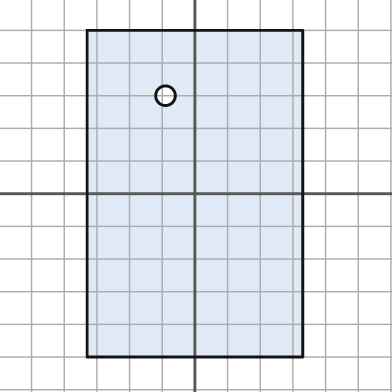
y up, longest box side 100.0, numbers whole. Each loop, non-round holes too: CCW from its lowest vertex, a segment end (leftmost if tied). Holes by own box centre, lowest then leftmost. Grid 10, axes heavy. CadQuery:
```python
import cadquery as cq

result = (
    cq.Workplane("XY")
    .moveTo(-33.0, -50.0)
    .lineTo(33.0, -50.0)
    .lineTo(33.0, 50.0)
    .lineTo(-33.0, 50.0)
    .close()
    .moveTo(-9.0, 30.0)
    .circle(3.0)
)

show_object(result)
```